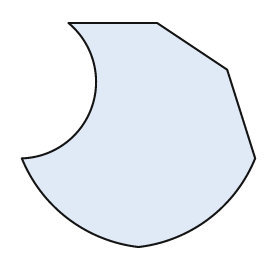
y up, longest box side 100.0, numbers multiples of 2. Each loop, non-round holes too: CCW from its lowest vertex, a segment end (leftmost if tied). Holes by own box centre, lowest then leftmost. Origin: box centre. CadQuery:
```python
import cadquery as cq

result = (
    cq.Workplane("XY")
    .moveTo(0.0, -48.0)
    .threePointArc((30.0, -36.0), (50.0, -10.0))
    .lineTo(38.0, 28.0)
    .lineTo(8.0, 48.0)
    .lineTo(-30.0, 48.0)
    .threePointArc((-20.0, 12.0), (-50.0, -10.0))
    .threePointArc((-30.0, -36.0), (0.0, -48.0))
    .close()
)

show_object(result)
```